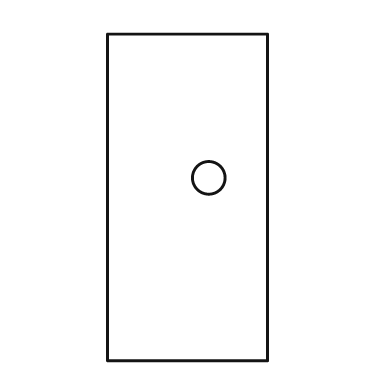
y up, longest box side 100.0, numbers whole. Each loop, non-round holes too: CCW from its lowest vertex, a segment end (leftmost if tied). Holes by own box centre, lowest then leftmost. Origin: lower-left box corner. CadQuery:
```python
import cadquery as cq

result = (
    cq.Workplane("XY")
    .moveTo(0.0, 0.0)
    .lineTo(49.0, 0.0)
    .lineTo(49.0, 100.0)
    .lineTo(0.0, 100.0)
    .close()
    .moveTo(31.0, 56.0)
    .circle(5.0)
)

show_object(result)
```